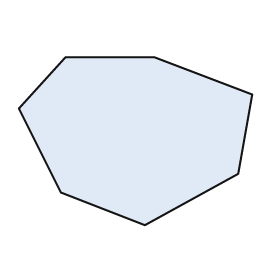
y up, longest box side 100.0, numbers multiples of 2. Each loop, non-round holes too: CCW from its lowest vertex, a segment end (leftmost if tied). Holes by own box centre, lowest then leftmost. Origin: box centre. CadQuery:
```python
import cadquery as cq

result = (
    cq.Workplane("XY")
    .moveTo(4.0, -36.0)
    .lineTo(44.0, -14.0)
    .lineTo(50.0, 20.0)
    .lineTo(8.0, 36.0)
    .lineTo(-30.0, 36.0)
    .lineTo(-50.0, 14.0)
    .lineTo(-32.0, -22.0)
    .close()
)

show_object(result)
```